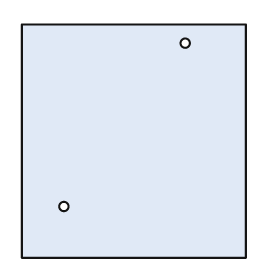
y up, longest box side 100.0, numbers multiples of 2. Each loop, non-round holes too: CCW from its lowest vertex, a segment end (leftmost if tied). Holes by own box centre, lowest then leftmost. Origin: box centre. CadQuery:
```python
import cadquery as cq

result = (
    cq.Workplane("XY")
    .moveTo(-48.0, -50.0)
    .lineTo(48.0, -50.0)
    .lineTo(48.0, 50.0)
    .lineTo(-48.0, 50.0)
    .close()
    .moveTo(-30.0, -28.0)
    .circle(2.0)
    .moveTo(22.0, 42.0)
    .circle(2.0)
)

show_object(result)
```